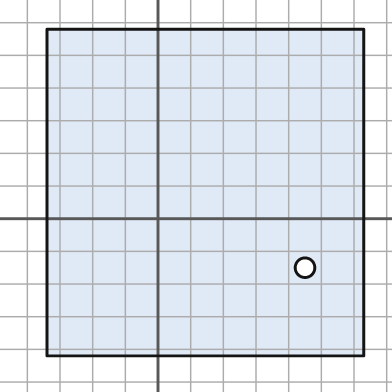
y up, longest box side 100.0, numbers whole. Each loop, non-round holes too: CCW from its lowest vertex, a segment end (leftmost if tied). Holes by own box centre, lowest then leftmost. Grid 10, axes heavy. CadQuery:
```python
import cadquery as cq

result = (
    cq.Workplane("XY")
    .moveTo(-34.0, -42.0)
    .lineTo(63.0, -42.0)
    .lineTo(63.0, 58.0)
    .lineTo(-34.0, 58.0)
    .close()
    .moveTo(45.0, -15.0)
    .circle(3.0)
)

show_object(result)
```